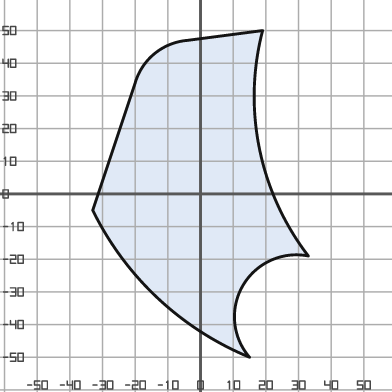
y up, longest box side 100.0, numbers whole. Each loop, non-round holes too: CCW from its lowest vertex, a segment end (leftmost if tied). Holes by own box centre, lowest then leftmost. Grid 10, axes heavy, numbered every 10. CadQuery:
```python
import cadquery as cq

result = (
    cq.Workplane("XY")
    .moveTo(15.0, -50.0)
    .threePointArc((13.0, -28.0), (33.0, -19.0))
    .threePointArc((18.0, 14.0), (19.0, 50.0))
    .lineTo(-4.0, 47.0)
    .threePointArc((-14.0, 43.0), (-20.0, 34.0))
    .lineTo(-33.0, -5.0)
    .threePointArc((-13.0, -32.0), (15.0, -50.0))
    .close()
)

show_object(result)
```